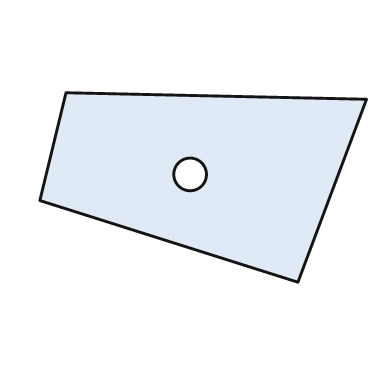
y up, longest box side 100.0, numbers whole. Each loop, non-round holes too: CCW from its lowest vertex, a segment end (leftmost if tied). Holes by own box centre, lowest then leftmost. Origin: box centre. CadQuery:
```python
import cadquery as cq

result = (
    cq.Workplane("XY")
    .moveTo(29.0, -29.0)
    .lineTo(50.0, 27.0)
    .lineTo(-42.0, 29.0)
    .lineTo(-50.0, -4.0)
    .close()
    .moveTo(-4.0, 4.0)
    .circle(5.0)
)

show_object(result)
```